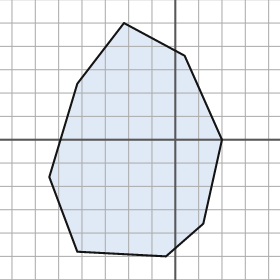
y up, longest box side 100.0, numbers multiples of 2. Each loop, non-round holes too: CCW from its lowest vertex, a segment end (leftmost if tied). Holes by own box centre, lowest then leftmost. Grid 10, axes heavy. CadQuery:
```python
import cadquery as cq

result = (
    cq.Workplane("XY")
    .moveTo(-4.0, -50.0)
    .lineTo(12.0, -36.0)
    .lineTo(20.0, 0.0)
    .lineTo(4.0, 36.0)
    .lineTo(-22.0, 50.0)
    .lineTo(-42.0, 24.0)
    .lineTo(-54.0, -16.0)
    .lineTo(-42.0, -48.0)
    .close()
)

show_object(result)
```